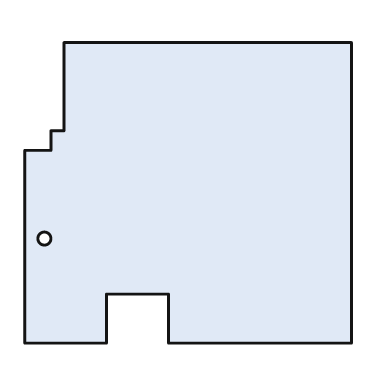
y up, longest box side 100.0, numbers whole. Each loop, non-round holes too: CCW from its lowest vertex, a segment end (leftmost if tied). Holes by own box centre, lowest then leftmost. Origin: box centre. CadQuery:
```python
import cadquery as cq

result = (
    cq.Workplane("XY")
    .moveTo(-50.0, -46.0)
    .lineTo(-25.0, -46.0)
    .lineTo(-25.0, -31.0)
    .lineTo(-6.0, -31.0)
    .lineTo(-6.0, -46.0)
    .lineTo(50.0, -46.0)
    .lineTo(50.0, 46.0)
    .lineTo(-38.0, 46.0)
    .lineTo(-38.0, 19.0)
    .lineTo(-42.0, 19.0)
    .lineTo(-42.0, 13.0)
    .lineTo(-50.0, 13.0)
    .close()
    .moveTo(-44.0, -14.0)
    .circle(2.0)
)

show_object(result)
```